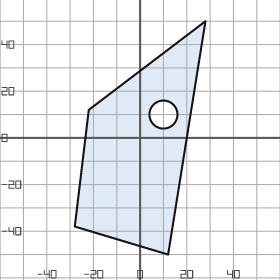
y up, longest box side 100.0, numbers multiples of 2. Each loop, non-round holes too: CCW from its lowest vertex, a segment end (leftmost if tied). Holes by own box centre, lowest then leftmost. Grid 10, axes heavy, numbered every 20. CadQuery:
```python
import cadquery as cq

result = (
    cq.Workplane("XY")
    .moveTo(12.0, -50.0)
    .lineTo(28.0, 50.0)
    .lineTo(-22.0, 12.0)
    .lineTo(-28.0, -38.0)
    .close()
    .moveTo(10.0, 10.0)
    .circle(6.0)
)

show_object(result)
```